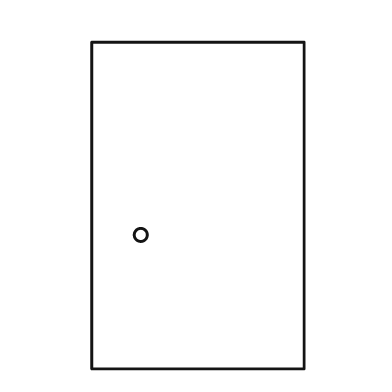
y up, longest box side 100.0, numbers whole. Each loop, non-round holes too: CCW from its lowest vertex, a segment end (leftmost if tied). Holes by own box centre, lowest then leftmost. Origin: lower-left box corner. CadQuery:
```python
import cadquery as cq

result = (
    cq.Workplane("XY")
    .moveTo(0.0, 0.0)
    .lineTo(65.0, 0.0)
    .lineTo(65.0, 100.0)
    .lineTo(0.0, 100.0)
    .close()
    .moveTo(15.0, 41.0)
    .circle(2.0)
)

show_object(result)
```